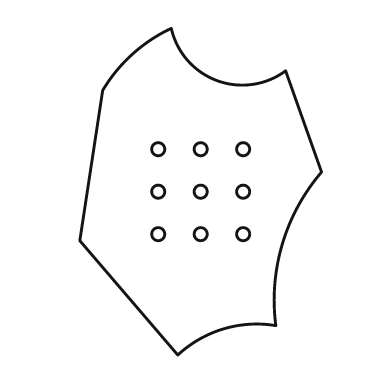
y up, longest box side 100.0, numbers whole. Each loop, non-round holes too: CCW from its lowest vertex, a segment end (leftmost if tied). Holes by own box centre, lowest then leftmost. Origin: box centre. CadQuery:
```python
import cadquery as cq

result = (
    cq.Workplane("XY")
    .moveTo(-7.0, -50.0)
    .threePointArc((7.0, -42.0), (23.0, -41.0))
    .threePointArc((25.0, -16.0), (37.0, 6.0))
    .lineTo(26.0, 37.0)
    .threePointArc((5.0, 34.0), (-9.0, 50.0))
    .threePointArc((-21.0, 42.0), (-30.0, 31.0))
    .lineTo(-37.0, -15.0)
    .close()
    .moveTo(-13.0, -13.0)
    .circle(2.0)
    .moveTo(0.0, -13.0)
    .circle(2.0)
    .moveTo(13.0, -13.0)
    .circle(2.0)
    .moveTo(-13.0, 0.0)
    .circle(2.0)
    .moveTo(0.0, 0.0)
    .circle(2.0)
    .moveTo(13.0, 0.0)
    .circle(2.0)
    .moveTo(-13.0, 13.0)
    .circle(2.0)
    .moveTo(0.0, 13.0)
    .circle(2.0)
    .moveTo(13.0, 13.0)
    .circle(2.0)
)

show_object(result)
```